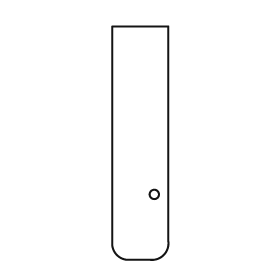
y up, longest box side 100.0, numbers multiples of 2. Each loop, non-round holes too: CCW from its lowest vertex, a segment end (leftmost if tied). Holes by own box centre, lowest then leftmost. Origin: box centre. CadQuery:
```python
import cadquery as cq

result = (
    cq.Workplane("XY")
    .moveTo(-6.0, -50.0)
    .lineTo(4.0, -50.0)
    .threePointArc((10.0, -48.0), (12.0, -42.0))
    .lineTo(12.0, 50.0)
    .lineTo(-12.0, 50.0)
    .lineTo(-12.0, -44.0)
    .threePointArc((-10.0, -48.0), (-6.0, -50.0))
    .close()
    .moveTo(6.0, -22.0)
    .circle(2.0)
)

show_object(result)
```